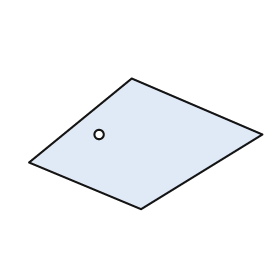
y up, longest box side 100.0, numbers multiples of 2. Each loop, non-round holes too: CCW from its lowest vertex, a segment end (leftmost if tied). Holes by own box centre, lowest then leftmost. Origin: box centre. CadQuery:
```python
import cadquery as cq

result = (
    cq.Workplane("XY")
    .moveTo(-2.0, -28.0)
    .lineTo(50.0, 4.0)
    .lineTo(-6.0, 28.0)
    .lineTo(-50.0, -8.0)
    .close()
    .moveTo(-20.0, 4.0)
    .circle(2.0)
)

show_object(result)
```